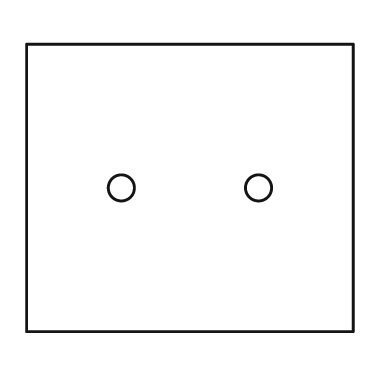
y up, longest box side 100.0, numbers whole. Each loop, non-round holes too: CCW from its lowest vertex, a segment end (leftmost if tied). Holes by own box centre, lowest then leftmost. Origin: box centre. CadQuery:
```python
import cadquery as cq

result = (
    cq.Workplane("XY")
    .moveTo(-50.0, -44.0)
    .lineTo(50.0, -44.0)
    .lineTo(50.0, 44.0)
    .lineTo(-50.0, 44.0)
    .close()
    .moveTo(-21.0, 0.0)
    .circle(4.0)
    .moveTo(21.0, 0.0)
    .circle(4.0)
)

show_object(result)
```